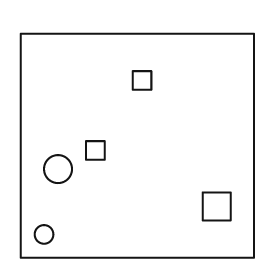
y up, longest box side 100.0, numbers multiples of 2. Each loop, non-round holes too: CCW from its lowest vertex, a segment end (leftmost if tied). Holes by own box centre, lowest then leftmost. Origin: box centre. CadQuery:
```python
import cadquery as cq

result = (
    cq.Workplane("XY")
    .moveTo(-50.0, -48.0)
    .lineTo(50.0, -48.0)
    .lineTo(50.0, 48.0)
    .lineTo(-50.0, 48.0)
    .close()
    .moveTo(-40.0, -38.0)
    .circle(4.0)
    .moveTo(28.0, -32.0)
    .lineTo(40.0, -32.0)
    .lineTo(40.0, -20.0)
    .lineTo(28.0, -20.0)
    .close()
    .moveTo(-34.0, -10.0)
    .circle(6.0)
    .moveTo(-22.0, -6.0)
    .lineTo(-14.0, -6.0)
    .lineTo(-14.0, 2.0)
    .lineTo(-22.0, 2.0)
    .close()
    .moveTo(-2.0, 24.0)
    .lineTo(6.0, 24.0)
    .lineTo(6.0, 32.0)
    .lineTo(-2.0, 32.0)
    .close()
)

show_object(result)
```